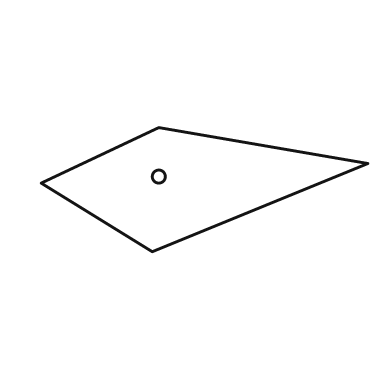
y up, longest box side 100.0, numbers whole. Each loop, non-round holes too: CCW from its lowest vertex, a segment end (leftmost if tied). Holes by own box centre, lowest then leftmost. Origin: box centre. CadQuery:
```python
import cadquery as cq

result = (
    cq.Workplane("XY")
    .moveTo(-16.0, -19.0)
    .lineTo(50.0, 8.0)
    .lineTo(-14.0, 19.0)
    .lineTo(-50.0, 2.0)
    .close()
    .moveTo(-14.0, 4.0)
    .circle(2.0)
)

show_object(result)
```